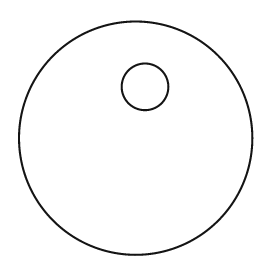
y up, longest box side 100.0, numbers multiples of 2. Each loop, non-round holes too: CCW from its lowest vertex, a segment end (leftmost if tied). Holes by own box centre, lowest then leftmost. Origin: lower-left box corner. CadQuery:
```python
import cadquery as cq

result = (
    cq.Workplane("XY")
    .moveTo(50.0, 50.0)
    .circle(50.0)
    .moveTo(54.0, 72.0)
    .circle(10.0)
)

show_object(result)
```